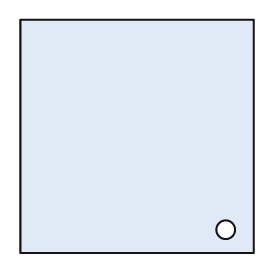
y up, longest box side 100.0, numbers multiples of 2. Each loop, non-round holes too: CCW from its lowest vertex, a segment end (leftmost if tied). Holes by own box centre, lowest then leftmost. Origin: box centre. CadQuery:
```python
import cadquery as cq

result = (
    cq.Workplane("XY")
    .moveTo(-50.0, -50.0)
    .lineTo(50.0, -50.0)
    .lineTo(50.0, 50.0)
    .lineTo(-50.0, 50.0)
    .close()
    .moveTo(38.0, -40.0)
    .circle(4.0)
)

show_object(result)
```